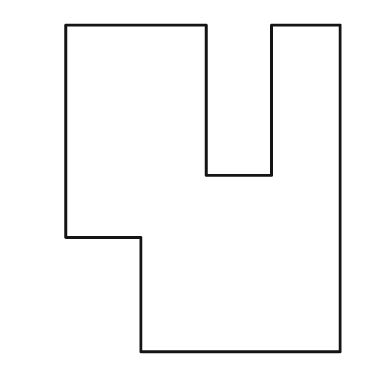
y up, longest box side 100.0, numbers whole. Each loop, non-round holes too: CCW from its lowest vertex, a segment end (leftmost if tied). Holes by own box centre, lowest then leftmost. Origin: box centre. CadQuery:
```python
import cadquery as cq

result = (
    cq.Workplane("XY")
    .moveTo(-19.0, -50.0)
    .lineTo(42.0, -50.0)
    .lineTo(42.0, 50.0)
    .lineTo(21.0, 50.0)
    .lineTo(21.0, 4.0)
    .lineTo(1.0, 4.0)
    .lineTo(1.0, 50.0)
    .lineTo(-42.0, 50.0)
    .lineTo(-42.0, -15.0)
    .lineTo(-19.0, -15.0)
    .close()
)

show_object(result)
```